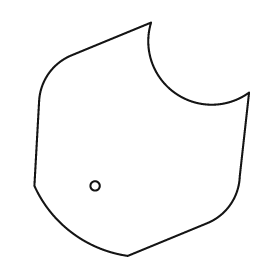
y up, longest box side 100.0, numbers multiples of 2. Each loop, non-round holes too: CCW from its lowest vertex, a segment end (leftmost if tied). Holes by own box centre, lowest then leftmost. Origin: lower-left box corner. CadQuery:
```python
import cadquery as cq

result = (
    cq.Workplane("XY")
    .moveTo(40.0, 0.0)
    .lineTo(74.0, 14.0)
    .threePointArc((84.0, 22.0), (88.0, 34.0))
    .lineTo(92.0, 70.0)
    .threePointArc((60.0, 70.0), (50.0, 100.0))
    .lineTo(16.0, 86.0)
    .threePointArc((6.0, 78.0), (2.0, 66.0))
    .lineTo(0.0, 30.0)
    .threePointArc((16.0, 10.0), (40.0, 0.0))
    .close()
    .moveTo(26.0, 30.0)
    .circle(2.0)
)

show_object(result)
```